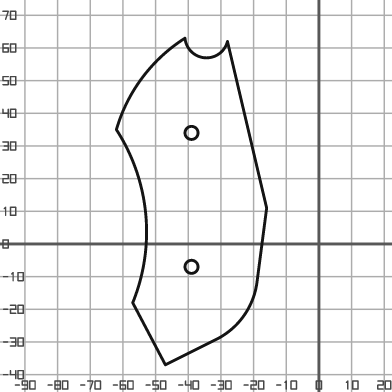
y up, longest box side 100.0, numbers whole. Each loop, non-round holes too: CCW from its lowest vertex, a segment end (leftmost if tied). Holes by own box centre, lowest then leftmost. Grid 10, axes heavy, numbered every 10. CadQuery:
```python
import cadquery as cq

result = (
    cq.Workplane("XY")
    .moveTo(-47.0, -37.0)
    .lineTo(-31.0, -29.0)
    .threePointArc((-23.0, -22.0), (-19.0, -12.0))
    .lineTo(-16.0, 11.0)
    .lineTo(-28.0, 62.0)
    .threePointArc((-35.0, 57.0), (-41.0, 63.0))
    .threePointArc((-54.0, 51.0), (-62.0, 35.0))
    .threePointArc((-53.0, 9.0), (-57.0, -18.0))
    .close()
    .moveTo(-39.0, -7.0)
    .circle(2.0)
    .moveTo(-39.0, 34.0)
    .circle(2.0)
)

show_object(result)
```